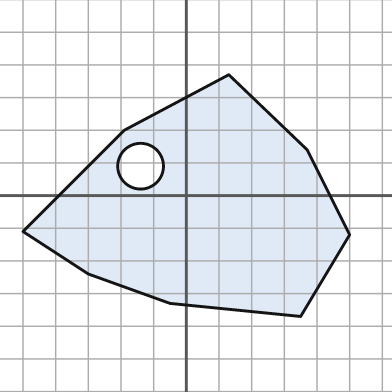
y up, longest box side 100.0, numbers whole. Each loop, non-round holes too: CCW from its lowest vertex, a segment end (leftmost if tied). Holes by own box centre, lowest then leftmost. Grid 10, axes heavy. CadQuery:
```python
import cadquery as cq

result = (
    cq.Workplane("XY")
    .moveTo(35.0, -37.0)
    .lineTo(50.0, -12.0)
    .lineTo(37.0, 14.0)
    .lineTo(13.0, 37.0)
    .lineTo(-19.0, 20.0)
    .lineTo(-50.0, -11.0)
    .lineTo(-30.0, -24.0)
    .lineTo(-5.0, -33.0)
    .close()
    .moveTo(-14.0, 9.0)
    .circle(7.0)
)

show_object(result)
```